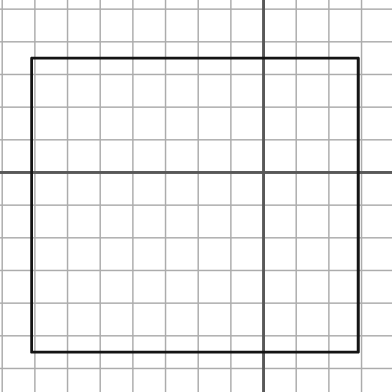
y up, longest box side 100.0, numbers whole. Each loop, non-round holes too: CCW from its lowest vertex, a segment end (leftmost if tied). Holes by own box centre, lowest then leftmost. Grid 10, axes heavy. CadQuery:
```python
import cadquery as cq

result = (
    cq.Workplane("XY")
    .moveTo(-71.0, -55.0)
    .lineTo(29.0, -55.0)
    .lineTo(29.0, 35.0)
    .lineTo(-71.0, 35.0)
    .close()
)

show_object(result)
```